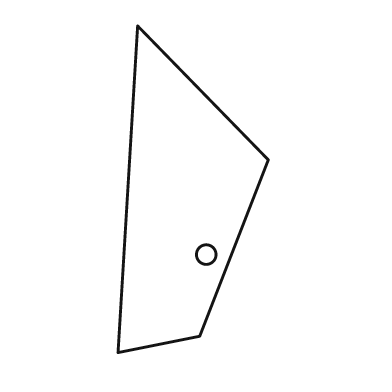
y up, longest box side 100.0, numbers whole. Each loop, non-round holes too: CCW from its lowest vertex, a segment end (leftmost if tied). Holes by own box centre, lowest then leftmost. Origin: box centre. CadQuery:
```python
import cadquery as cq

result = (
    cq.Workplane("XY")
    .moveTo(-23.0, -50.0)
    .lineTo(2.0, -45.0)
    .lineTo(23.0, 9.0)
    .lineTo(-17.0, 50.0)
    .close()
    .moveTo(4.0, -20.0)
    .circle(3.0)
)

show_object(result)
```